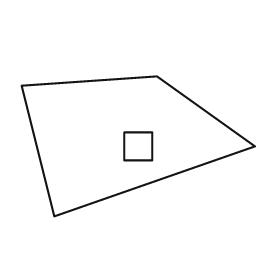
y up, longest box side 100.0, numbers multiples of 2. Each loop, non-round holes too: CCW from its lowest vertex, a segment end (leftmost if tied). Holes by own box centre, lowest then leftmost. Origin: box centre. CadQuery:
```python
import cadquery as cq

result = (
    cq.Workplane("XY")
    .moveTo(-36.0, -30.0)
    .lineTo(50.0, 0.0)
    .lineTo(8.0, 30.0)
    .lineTo(-50.0, 26.0)
    .close()
    .moveTo(-6.0, -6.0)
    .lineTo(6.0, -6.0)
    .lineTo(6.0, 6.0)
    .lineTo(-6.0, 6.0)
    .close()
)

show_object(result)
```